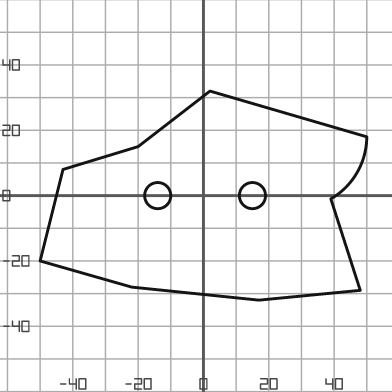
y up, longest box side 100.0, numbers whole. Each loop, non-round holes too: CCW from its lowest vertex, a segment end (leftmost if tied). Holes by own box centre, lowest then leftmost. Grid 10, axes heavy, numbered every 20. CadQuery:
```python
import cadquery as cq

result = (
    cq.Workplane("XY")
    .moveTo(17.0, -32.0)
    .lineTo(48.0, -29.0)
    .lineTo(39.0, -1.0)
    .threePointArc((47.0, 7.0), (50.0, 18.0))
    .lineTo(2.0, 32.0)
    .lineTo(-20.0, 15.0)
    .lineTo(-43.0, 8.0)
    .lineTo(-50.0, -20.0)
    .lineTo(-22.0, -28.0)
    .close()
    .moveTo(-14.0, 0.0)
    .circle(4.0)
    .moveTo(15.0, 0.0)
    .circle(4.0)
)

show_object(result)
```